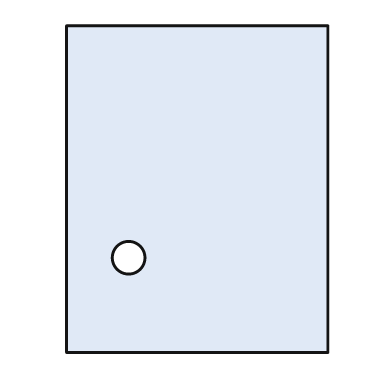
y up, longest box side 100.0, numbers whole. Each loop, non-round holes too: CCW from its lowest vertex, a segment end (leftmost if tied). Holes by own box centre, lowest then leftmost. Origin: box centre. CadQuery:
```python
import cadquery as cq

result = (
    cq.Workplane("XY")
    .moveTo(-40.0, -50.0)
    .lineTo(40.0, -50.0)
    .lineTo(40.0, 50.0)
    .lineTo(-40.0, 50.0)
    .close()
    .moveTo(-21.0, -21.0)
    .circle(5.0)
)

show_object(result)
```